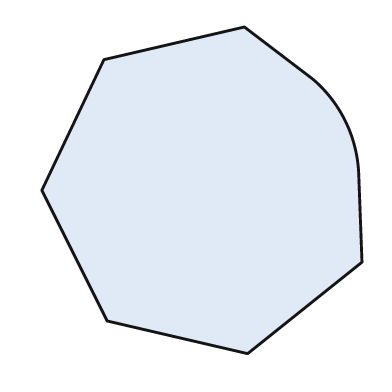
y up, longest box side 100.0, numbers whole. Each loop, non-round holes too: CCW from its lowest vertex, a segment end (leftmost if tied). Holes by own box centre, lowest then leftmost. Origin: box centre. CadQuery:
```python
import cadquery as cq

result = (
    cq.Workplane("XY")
    .moveTo(14.0, -50.0)
    .lineTo(49.0, -22.0)
    .lineTo(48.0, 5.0)
    .threePointArc((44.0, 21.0), (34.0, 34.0))
    .lineTo(13.0, 50.0)
    .lineTo(-30.0, 40.0)
    .lineTo(-49.0, 0.0)
    .lineTo(-29.0, -40.0)
    .close()
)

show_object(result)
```